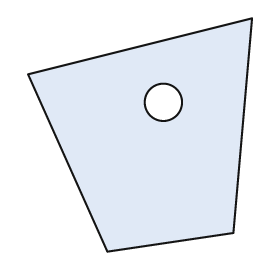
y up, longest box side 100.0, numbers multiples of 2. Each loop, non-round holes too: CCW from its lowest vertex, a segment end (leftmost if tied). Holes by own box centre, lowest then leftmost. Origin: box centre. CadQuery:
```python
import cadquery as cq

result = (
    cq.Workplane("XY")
    .moveTo(-14.0, -50.0)
    .lineTo(40.0, -42.0)
    .lineTo(48.0, 50.0)
    .lineTo(-48.0, 26.0)
    .close()
    .moveTo(10.0, 14.0)
    .circle(8.0)
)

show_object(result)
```